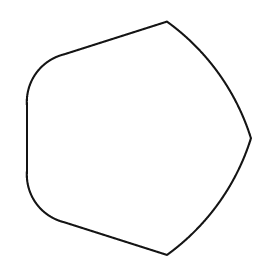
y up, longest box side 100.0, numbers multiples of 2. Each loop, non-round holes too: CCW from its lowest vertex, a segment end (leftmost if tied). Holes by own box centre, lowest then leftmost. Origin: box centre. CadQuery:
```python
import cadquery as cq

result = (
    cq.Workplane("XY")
    .moveTo(12.0, -50.0)
    .threePointArc((34.0, -28.0), (48.0, 0.0))
    .threePointArc((34.0, 28.0), (12.0, 50.0))
    .lineTo(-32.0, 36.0)
    .threePointArc((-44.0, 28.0), (-48.0, 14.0))
    .lineTo(-48.0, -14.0)
    .threePointArc((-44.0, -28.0), (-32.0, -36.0))
    .close()
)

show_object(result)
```